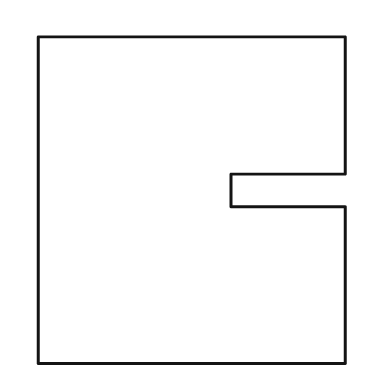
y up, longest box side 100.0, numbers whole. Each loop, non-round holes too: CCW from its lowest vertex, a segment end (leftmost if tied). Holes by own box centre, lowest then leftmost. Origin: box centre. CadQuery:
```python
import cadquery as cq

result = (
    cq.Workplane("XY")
    .moveTo(-47.0, -50.0)
    .lineTo(47.0, -50.0)
    .lineTo(47.0, -2.0)
    .lineTo(12.0, -2.0)
    .lineTo(12.0, 8.0)
    .lineTo(47.0, 8.0)
    .lineTo(47.0, 50.0)
    .lineTo(-47.0, 50.0)
    .close()
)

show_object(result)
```